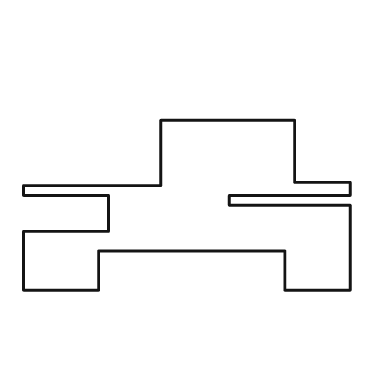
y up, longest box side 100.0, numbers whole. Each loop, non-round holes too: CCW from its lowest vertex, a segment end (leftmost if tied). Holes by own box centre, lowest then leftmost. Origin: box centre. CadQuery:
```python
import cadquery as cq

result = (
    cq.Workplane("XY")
    .moveTo(-50.0, -26.0)
    .lineTo(-27.0, -26.0)
    .lineTo(-27.0, -14.0)
    .lineTo(30.0, -14.0)
    .lineTo(30.0, -26.0)
    .lineTo(50.0, -26.0)
    .lineTo(50.0, 0.0)
    .lineTo(13.0, 0.0)
    .lineTo(13.0, 3.0)
    .lineTo(50.0, 3.0)
    .lineTo(50.0, 7.0)
    .lineTo(33.0, 7.0)
    .lineTo(33.0, 26.0)
    .lineTo(-8.0, 26.0)
    .lineTo(-8.0, 6.0)
    .lineTo(-50.0, 6.0)
    .lineTo(-50.0, 3.0)
    .lineTo(-24.0, 3.0)
    .lineTo(-24.0, -8.0)
    .lineTo(-50.0, -8.0)
    .close()
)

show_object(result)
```